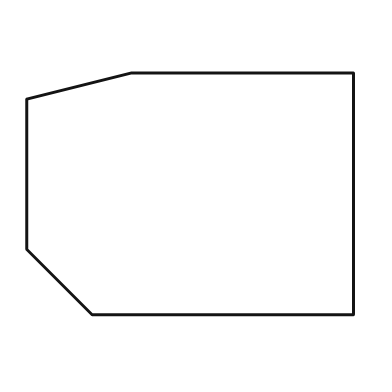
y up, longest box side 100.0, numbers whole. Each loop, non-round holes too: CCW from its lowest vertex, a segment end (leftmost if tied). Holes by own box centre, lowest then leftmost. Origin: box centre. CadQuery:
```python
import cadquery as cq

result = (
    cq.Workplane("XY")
    .moveTo(-30.0, -37.0)
    .lineTo(50.0, -37.0)
    .lineTo(50.0, 37.0)
    .lineTo(-18.0, 37.0)
    .lineTo(-50.0, 29.0)
    .lineTo(-50.0, -17.0)
    .close()
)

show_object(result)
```